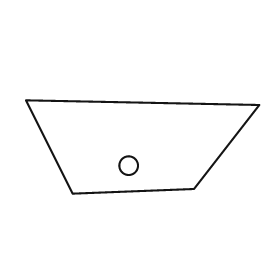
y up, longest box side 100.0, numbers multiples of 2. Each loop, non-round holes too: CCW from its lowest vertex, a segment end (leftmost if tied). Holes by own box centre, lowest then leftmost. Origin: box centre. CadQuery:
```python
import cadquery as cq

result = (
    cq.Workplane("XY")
    .moveTo(-30.0, -20.0)
    .lineTo(22.0, -18.0)
    .lineTo(50.0, 18.0)
    .lineTo(-50.0, 20.0)
    .close()
    .moveTo(-6.0, -8.0)
    .circle(4.0)
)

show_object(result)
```